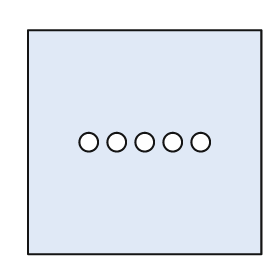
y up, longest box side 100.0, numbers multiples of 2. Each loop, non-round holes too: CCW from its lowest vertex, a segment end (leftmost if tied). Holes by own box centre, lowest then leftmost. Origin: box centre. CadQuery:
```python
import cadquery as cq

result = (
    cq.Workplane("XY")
    .moveTo(-50.0, -48.0)
    .lineTo(50.0, -48.0)
    .lineTo(50.0, 48.0)
    .lineTo(-50.0, 48.0)
    .close()
    .moveTo(-24.0, 0.0)
    .circle(4.0)
    .moveTo(-12.0, 0.0)
    .circle(4.0)
    .moveTo(0.0, 0.0)
    .circle(4.0)
    .moveTo(12.0, 0.0)
    .circle(4.0)
    .moveTo(24.0, 0.0)
    .circle(4.0)
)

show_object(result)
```